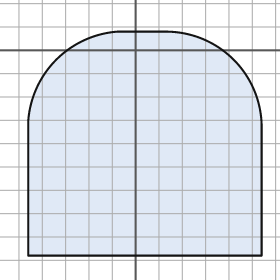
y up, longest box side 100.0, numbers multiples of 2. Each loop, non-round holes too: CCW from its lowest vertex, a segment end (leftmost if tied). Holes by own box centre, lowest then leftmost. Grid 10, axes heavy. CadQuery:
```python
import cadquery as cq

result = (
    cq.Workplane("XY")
    .moveTo(-46.0, -88.0)
    .lineTo(54.0, -88.0)
    .lineTo(54.0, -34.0)
    .threePointArc((42.0, -4.0), (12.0, 8.0))
    .lineTo(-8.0, 8.0)
    .threePointArc((-34.0, -4.0), (-46.0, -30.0))
    .close()
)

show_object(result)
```